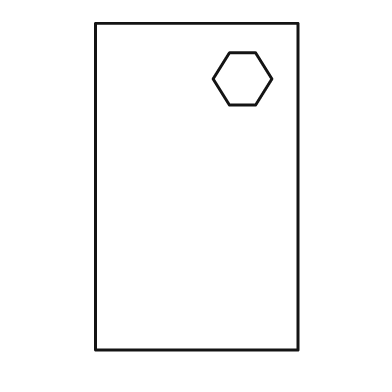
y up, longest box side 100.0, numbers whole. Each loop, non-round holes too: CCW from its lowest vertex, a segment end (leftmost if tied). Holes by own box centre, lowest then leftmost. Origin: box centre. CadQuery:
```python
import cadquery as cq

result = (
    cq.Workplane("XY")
    .moveTo(-31.0, -50.0)
    .lineTo(31.0, -50.0)
    .lineTo(31.0, 50.0)
    .lineTo(-31.0, 50.0)
    .close()
    .moveTo(10.0, 25.0)
    .lineTo(18.0, 25.0)
    .lineTo(23.0, 33.0)
    .lineTo(18.0, 41.0)
    .lineTo(10.0, 41.0)
    .lineTo(5.0, 33.0)
    .close()
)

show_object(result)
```